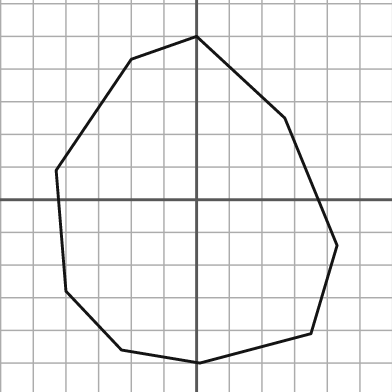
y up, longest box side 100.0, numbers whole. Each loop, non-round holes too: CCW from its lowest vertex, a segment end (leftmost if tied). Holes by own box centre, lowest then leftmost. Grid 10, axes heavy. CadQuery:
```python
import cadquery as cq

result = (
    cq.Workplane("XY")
    .moveTo(1.0, -50.0)
    .lineTo(35.0, -41.0)
    .lineTo(43.0, -14.0)
    .lineTo(27.0, 25.0)
    .lineTo(0.0, 50.0)
    .lineTo(-20.0, 43.0)
    .lineTo(-43.0, 9.0)
    .lineTo(-40.0, -28.0)
    .lineTo(-23.0, -46.0)
    .close()
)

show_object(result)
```